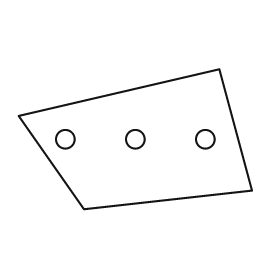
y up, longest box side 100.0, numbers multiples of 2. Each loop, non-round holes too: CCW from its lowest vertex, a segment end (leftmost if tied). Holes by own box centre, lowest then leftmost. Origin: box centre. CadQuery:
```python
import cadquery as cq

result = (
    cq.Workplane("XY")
    .moveTo(-22.0, -30.0)
    .lineTo(50.0, -22.0)
    .lineTo(36.0, 30.0)
    .lineTo(-50.0, 10.0)
    .close()
    .moveTo(-30.0, 0.0)
    .circle(4.0)
    .moveTo(0.0, 0.0)
    .circle(4.0)
    .moveTo(30.0, 0.0)
    .circle(4.0)
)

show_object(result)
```